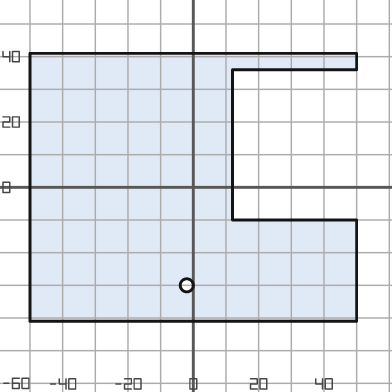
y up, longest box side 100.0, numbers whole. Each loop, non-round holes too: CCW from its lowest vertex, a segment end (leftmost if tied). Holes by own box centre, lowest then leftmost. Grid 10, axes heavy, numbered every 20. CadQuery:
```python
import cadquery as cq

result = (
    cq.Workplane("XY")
    .moveTo(-50.0, -41.0)
    .lineTo(50.0, -41.0)
    .lineTo(50.0, -10.0)
    .lineTo(12.0, -10.0)
    .lineTo(12.0, 36.0)
    .lineTo(50.0, 36.0)
    .lineTo(50.0, 41.0)
    .lineTo(-50.0, 41.0)
    .close()
    .moveTo(-2.0, -30.0)
    .circle(2.0)
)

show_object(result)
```